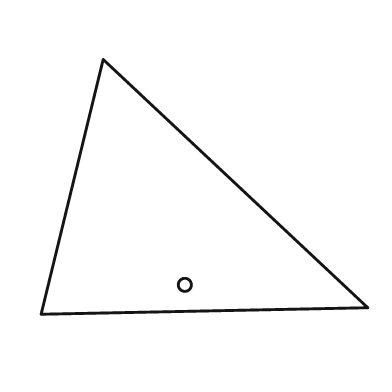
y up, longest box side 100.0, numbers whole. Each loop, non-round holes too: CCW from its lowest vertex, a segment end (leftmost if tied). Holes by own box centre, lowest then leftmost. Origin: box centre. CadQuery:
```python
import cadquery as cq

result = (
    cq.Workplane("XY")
    .moveTo(-50.0, -39.0)
    .lineTo(50.0, -37.0)
    .lineTo(-31.0, 39.0)
    .close()
    .moveTo(-6.0, -30.0)
    .circle(2.0)
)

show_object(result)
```